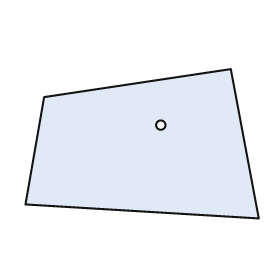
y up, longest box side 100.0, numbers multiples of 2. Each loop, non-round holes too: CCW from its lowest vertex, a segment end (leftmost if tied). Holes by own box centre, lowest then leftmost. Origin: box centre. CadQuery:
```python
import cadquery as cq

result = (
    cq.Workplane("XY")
    .moveTo(50.0, -32.0)
    .lineTo(38.0, 32.0)
    .lineTo(-42.0, 20.0)
    .lineTo(-50.0, -26.0)
    .close()
    .moveTo(8.0, 8.0)
    .circle(2.0)
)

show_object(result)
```